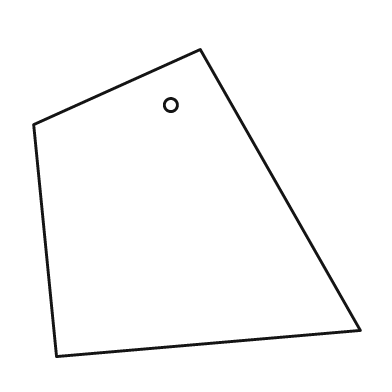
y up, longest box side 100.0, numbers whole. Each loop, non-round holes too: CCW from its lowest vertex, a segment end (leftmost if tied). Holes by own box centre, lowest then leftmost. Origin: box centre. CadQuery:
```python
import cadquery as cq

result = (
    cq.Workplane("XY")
    .moveTo(-43.0, -47.0)
    .lineTo(50.0, -39.0)
    .lineTo(1.0, 47.0)
    .lineTo(-50.0, 24.0)
    .close()
    .moveTo(-8.0, 30.0)
    .circle(2.0)
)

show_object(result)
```